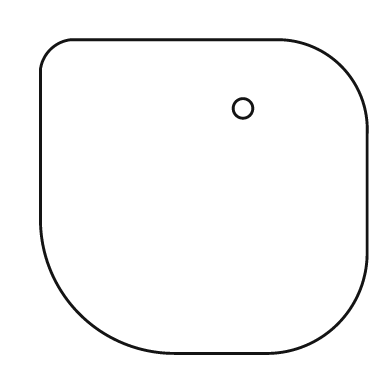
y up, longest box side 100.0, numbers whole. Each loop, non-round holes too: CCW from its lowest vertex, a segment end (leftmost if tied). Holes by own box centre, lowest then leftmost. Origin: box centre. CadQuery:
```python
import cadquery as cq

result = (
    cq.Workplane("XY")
    .moveTo(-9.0, -48.0)
    .lineTo(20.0, -48.0)
    .threePointArc((41.0, -39.0), (50.0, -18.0))
    .lineTo(50.0, 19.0)
    .threePointArc((42.0, 40.0), (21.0, 48.0))
    .lineTo(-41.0, 48.0)
    .threePointArc((-47.0, 45.0), (-50.0, 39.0))
    .lineTo(-50.0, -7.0)
    .threePointArc((-38.0, -36.0), (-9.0, -48.0))
    .close()
    .moveTo(12.0, 27.0)
    .circle(3.0)
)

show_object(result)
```